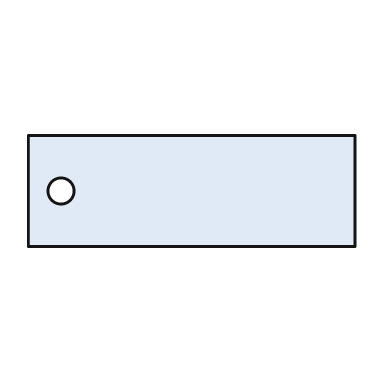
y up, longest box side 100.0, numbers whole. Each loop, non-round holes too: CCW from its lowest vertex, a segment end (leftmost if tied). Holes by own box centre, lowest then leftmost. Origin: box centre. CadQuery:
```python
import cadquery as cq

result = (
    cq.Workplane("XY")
    .moveTo(-50.0, -17.0)
    .lineTo(50.0, -17.0)
    .lineTo(50.0, 17.0)
    .lineTo(-50.0, 17.0)
    .close()
    .moveTo(-40.0, 0.0)
    .circle(4.0)
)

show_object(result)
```